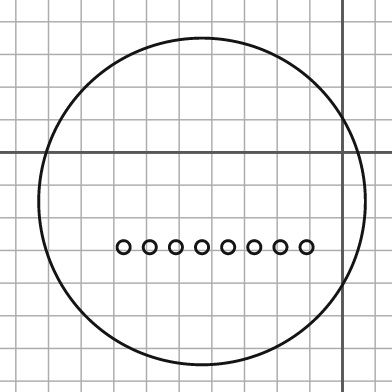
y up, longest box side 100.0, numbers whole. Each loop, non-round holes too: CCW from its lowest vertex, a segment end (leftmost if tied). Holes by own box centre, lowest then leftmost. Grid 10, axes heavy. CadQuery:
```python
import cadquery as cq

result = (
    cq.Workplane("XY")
    .moveTo(-43.0, -15.0)
    .circle(50.0)
    .moveTo(-67.0, -29.0)
    .circle(2.0)
    .moveTo(-59.0, -29.0)
    .circle(2.0)
    .moveTo(-51.0, -29.0)
    .circle(2.0)
    .moveTo(-43.0, -29.0)
    .circle(2.0)
    .moveTo(-35.0, -29.0)
    .circle(2.0)
    .moveTo(-27.0, -29.0)
    .circle(2.0)
    .moveTo(-19.0, -29.0)
    .circle(2.0)
    .moveTo(-11.0, -29.0)
    .circle(2.0)
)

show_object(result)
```